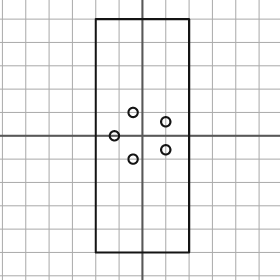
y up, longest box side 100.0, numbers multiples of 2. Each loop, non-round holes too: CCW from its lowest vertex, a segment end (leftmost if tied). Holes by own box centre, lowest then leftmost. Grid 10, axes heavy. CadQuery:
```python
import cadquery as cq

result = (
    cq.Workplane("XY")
    .moveTo(-20.0, -50.0)
    .lineTo(20.0, -50.0)
    .lineTo(20.0, 50.0)
    .lineTo(-20.0, 50.0)
    .close()
    .moveTo(-4.0, -10.0)
    .circle(2.0)
    .moveTo(10.0, -6.0)
    .circle(2.0)
    .moveTo(-12.0, 0.0)
    .circle(2.0)
    .moveTo(10.0, 6.0)
    .circle(2.0)
    .moveTo(-4.0, 10.0)
    .circle(2.0)
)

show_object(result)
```